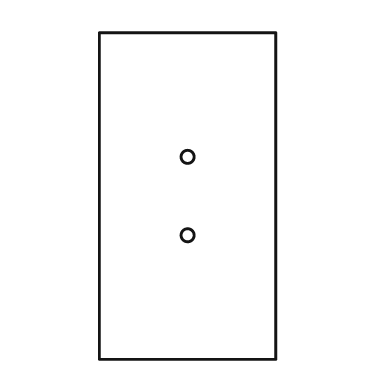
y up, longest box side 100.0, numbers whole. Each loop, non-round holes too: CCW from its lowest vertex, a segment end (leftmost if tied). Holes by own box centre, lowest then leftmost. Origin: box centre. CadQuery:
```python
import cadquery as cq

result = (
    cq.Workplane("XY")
    .moveTo(-27.0, -50.0)
    .lineTo(27.0, -50.0)
    .lineTo(27.0, 50.0)
    .lineTo(-27.0, 50.0)
    .close()
    .moveTo(0.0, -12.0)
    .circle(2.0)
    .moveTo(0.0, 12.0)
    .circle(2.0)
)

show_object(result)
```